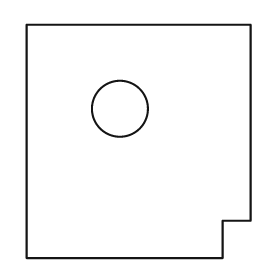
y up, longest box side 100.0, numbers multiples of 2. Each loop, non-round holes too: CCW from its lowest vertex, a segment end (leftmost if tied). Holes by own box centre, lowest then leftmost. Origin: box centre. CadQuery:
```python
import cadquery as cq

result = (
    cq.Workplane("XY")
    .moveTo(-48.0, -50.0)
    .lineTo(36.0, -50.0)
    .lineTo(36.0, -34.0)
    .lineTo(48.0, -34.0)
    .lineTo(48.0, 50.0)
    .lineTo(-48.0, 50.0)
    .close()
    .moveTo(-8.0, 14.0)
    .circle(12.0)
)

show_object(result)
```